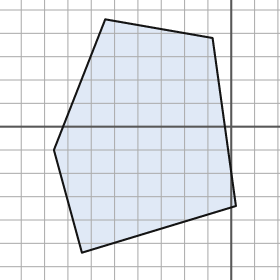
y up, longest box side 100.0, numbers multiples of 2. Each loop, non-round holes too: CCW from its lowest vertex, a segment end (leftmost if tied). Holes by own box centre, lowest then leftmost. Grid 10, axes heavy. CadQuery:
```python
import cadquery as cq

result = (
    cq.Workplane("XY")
    .moveTo(-64.0, -54.0)
    .lineTo(2.0, -34.0)
    .lineTo(-8.0, 38.0)
    .lineTo(-54.0, 46.0)
    .lineTo(-76.0, -10.0)
    .close()
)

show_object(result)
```